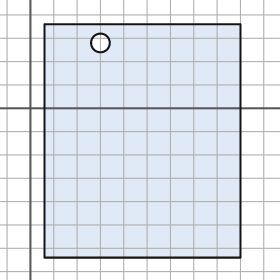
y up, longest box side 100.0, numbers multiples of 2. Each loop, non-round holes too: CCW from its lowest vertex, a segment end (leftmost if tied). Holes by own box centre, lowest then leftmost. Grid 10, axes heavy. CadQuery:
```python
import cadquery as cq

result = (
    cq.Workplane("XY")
    .moveTo(6.0, -64.0)
    .lineTo(90.0, -64.0)
    .lineTo(90.0, 36.0)
    .lineTo(6.0, 36.0)
    .close()
    .moveTo(30.0, 28.0)
    .circle(4.0)
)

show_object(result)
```